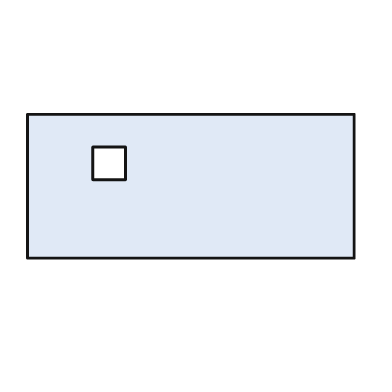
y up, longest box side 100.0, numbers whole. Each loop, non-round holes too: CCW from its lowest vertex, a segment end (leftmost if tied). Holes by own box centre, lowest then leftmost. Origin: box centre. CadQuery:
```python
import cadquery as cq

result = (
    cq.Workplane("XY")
    .moveTo(-50.0, -22.0)
    .lineTo(50.0, -22.0)
    .lineTo(50.0, 22.0)
    .lineTo(-50.0, 22.0)
    .close()
    .moveTo(-30.0, 2.0)
    .lineTo(-20.0, 2.0)
    .lineTo(-20.0, 12.0)
    .lineTo(-30.0, 12.0)
    .close()
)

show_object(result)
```